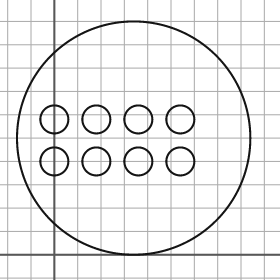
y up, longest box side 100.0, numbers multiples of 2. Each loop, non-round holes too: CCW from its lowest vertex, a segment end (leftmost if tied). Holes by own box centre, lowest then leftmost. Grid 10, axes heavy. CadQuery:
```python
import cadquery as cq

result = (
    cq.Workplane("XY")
    .moveTo(34.0, 50.0)
    .circle(50.0)
    .moveTo(0.0, 40.0)
    .circle(6.0)
    .moveTo(18.0, 40.0)
    .circle(6.0)
    .moveTo(36.0, 40.0)
    .circle(6.0)
    .moveTo(54.0, 40.0)
    .circle(6.0)
    .moveTo(0.0, 58.0)
    .circle(6.0)
    .moveTo(18.0, 58.0)
    .circle(6.0)
    .moveTo(36.0, 58.0)
    .circle(6.0)
    .moveTo(54.0, 58.0)
    .circle(6.0)
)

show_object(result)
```